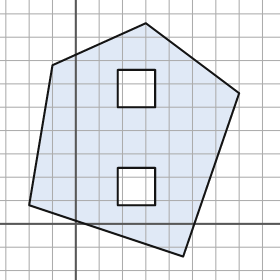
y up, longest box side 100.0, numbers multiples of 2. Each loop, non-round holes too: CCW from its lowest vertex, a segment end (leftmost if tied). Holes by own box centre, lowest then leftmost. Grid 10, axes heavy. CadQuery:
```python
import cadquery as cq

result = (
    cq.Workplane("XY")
    .moveTo(46.0, -14.0)
    .lineTo(70.0, 56.0)
    .lineTo(30.0, 86.0)
    .lineTo(-10.0, 68.0)
    .lineTo(-20.0, 8.0)
    .close()
    .moveTo(18.0, 8.0)
    .lineTo(34.0, 8.0)
    .lineTo(34.0, 24.0)
    .lineTo(18.0, 24.0)
    .close()
    .moveTo(18.0, 50.0)
    .lineTo(34.0, 50.0)
    .lineTo(34.0, 66.0)
    .lineTo(18.0, 66.0)
    .close()
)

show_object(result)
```